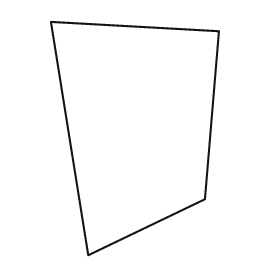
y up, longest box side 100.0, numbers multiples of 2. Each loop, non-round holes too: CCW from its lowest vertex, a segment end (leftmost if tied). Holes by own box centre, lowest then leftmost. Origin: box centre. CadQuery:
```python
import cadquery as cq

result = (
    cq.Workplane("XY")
    .moveTo(-20.0, -50.0)
    .lineTo(30.0, -26.0)
    .lineTo(36.0, 46.0)
    .lineTo(-36.0, 50.0)
    .close()
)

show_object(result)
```